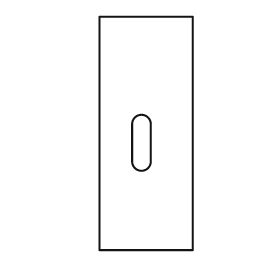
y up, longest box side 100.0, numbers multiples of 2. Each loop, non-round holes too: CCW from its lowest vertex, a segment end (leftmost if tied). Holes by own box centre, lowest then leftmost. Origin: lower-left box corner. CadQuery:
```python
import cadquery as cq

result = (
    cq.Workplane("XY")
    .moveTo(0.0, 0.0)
    .lineTo(40.0, 0.0)
    .lineTo(40.0, 100.0)
    .lineTo(0.0, 100.0)
    .close()
    .moveTo(14.0, 38.0)
    .threePointArc((18.0, 34.0), (22.0, 38.0))
    .lineTo(22.0, 54.0)
    .threePointArc((18.0, 58.0), (14.0, 54.0))
    .close()
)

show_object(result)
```